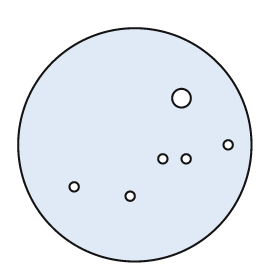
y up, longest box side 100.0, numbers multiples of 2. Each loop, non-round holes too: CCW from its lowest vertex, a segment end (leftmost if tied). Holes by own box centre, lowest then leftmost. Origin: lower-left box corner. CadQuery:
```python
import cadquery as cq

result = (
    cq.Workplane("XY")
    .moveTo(50.0, 50.0)
    .circle(50.0)
    .moveTo(48.0, 28.0)
    .circle(2.0)
    .moveTo(24.0, 32.0)
    .circle(2.0)
    .moveTo(62.0, 44.0)
    .circle(2.0)
    .moveTo(72.0, 44.0)
    .circle(2.0)
    .moveTo(90.0, 50.0)
    .circle(2.0)
    .moveTo(70.0, 70.0)
    .circle(4.0)
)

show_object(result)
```